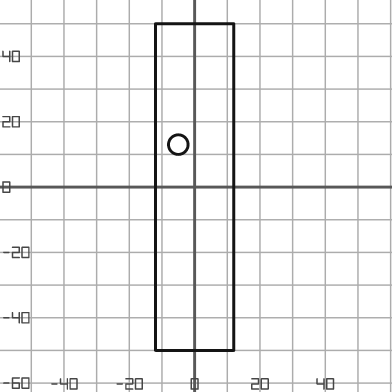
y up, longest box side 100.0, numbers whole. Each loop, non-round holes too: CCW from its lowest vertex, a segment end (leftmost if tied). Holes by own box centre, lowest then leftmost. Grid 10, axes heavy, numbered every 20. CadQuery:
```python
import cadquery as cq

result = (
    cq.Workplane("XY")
    .moveTo(-12.0, -50.0)
    .lineTo(12.0, -50.0)
    .lineTo(12.0, 50.0)
    .lineTo(-12.0, 50.0)
    .close()
    .moveTo(-5.0, 13.0)
    .circle(3.0)
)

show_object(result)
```